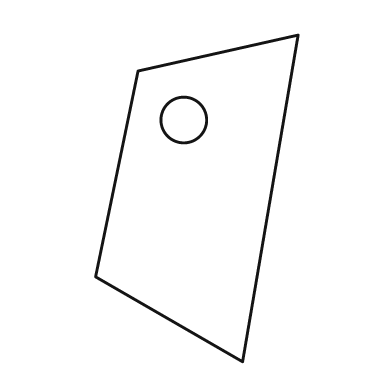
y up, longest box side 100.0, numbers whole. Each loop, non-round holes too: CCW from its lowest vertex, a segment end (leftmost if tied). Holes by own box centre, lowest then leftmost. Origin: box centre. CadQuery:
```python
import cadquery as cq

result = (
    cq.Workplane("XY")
    .moveTo(14.0, -50.0)
    .lineTo(31.0, 50.0)
    .lineTo(-18.0, 39.0)
    .lineTo(-31.0, -24.0)
    .close()
    .moveTo(-4.0, 24.0)
    .circle(7.0)
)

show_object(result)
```